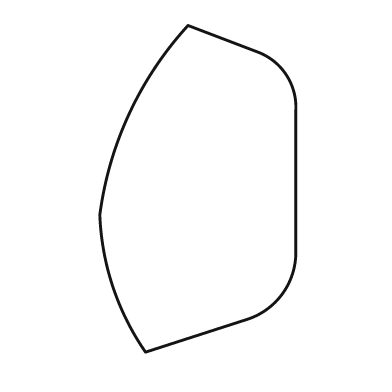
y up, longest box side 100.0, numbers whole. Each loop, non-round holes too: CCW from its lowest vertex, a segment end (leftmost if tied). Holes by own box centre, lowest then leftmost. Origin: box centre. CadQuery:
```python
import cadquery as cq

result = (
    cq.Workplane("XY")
    .moveTo(-16.0, -50.0)
    .lineTo(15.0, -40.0)
    .threePointArc((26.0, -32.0), (30.0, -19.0))
    .lineTo(30.0, 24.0)
    .threePointArc((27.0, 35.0), (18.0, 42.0))
    .lineTo(-3.0, 50.0)
    .threePointArc((-21.0, 23.0), (-30.0, -8.0))
    .threePointArc((-26.0, -30.0), (-16.0, -50.0))
    .close()
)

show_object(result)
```